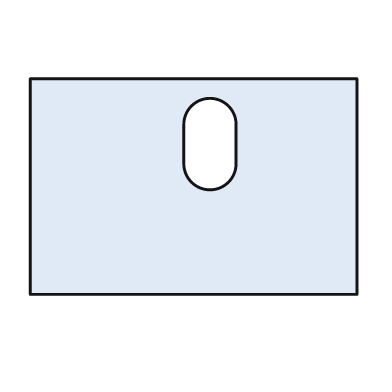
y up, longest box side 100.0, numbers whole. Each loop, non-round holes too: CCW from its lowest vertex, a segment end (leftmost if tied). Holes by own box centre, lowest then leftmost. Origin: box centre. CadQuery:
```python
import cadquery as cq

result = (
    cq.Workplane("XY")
    .moveTo(-50.0, -33.0)
    .lineTo(50.0, -33.0)
    .lineTo(50.0, 33.0)
    .lineTo(-50.0, 33.0)
    .close()
    .moveTo(-3.0, 7.0)
    .threePointArc((5.0, -1.0), (13.0, 7.0))
    .lineTo(13.0, 19.0)
    .threePointArc((5.0, 27.0), (-3.0, 19.0))
    .close()
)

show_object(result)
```